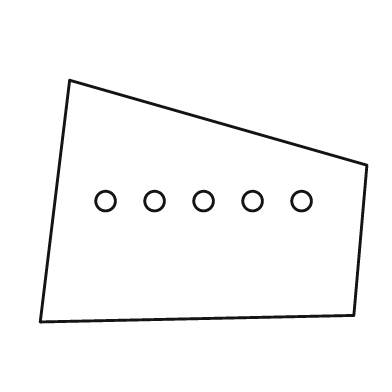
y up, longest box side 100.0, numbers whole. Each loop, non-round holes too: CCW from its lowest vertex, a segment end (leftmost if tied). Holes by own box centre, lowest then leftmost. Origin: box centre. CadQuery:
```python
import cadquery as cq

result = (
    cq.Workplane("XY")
    .moveTo(-50.0, -37.0)
    .lineTo(46.0, -35.0)
    .lineTo(50.0, 11.0)
    .lineTo(-41.0, 37.0)
    .close()
    .moveTo(-30.0, 0.0)
    .circle(3.0)
    .moveTo(-15.0, 0.0)
    .circle(3.0)
    .moveTo(0.0, 0.0)
    .circle(3.0)
    .moveTo(15.0, 0.0)
    .circle(3.0)
    .moveTo(30.0, 0.0)
    .circle(3.0)
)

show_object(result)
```